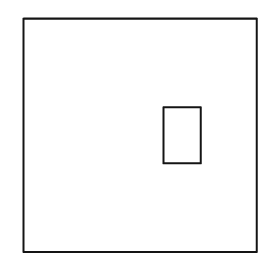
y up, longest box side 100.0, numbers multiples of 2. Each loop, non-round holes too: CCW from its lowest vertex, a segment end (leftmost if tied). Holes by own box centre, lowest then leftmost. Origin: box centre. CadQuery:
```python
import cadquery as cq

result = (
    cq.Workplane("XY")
    .moveTo(-50.0, -50.0)
    .lineTo(50.0, -50.0)
    .lineTo(50.0, 50.0)
    .lineTo(-50.0, 50.0)
    .close()
    .moveTo(10.0, -12.0)
    .lineTo(26.0, -12.0)
    .lineTo(26.0, 12.0)
    .lineTo(10.0, 12.0)
    .close()
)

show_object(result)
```